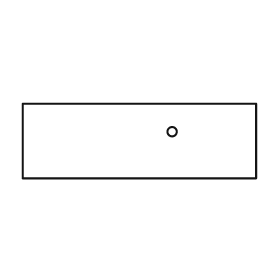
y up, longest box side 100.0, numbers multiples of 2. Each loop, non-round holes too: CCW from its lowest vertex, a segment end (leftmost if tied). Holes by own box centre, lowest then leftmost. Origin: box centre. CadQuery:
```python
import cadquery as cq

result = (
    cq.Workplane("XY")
    .moveTo(-50.0, -16.0)
    .lineTo(50.0, -16.0)
    .lineTo(50.0, 16.0)
    .lineTo(-50.0, 16.0)
    .close()
    .moveTo(14.0, 4.0)
    .circle(2.0)
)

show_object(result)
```